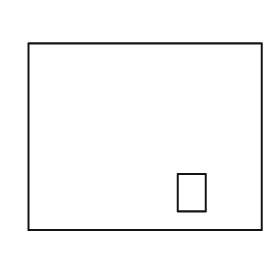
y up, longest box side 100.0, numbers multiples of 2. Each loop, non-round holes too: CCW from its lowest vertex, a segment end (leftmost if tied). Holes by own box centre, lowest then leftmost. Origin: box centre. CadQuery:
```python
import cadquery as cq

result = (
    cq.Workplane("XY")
    .moveTo(-50.0, -40.0)
    .lineTo(50.0, -40.0)
    .lineTo(50.0, 40.0)
    .lineTo(-50.0, 40.0)
    .close()
    .moveTo(14.0, -32.0)
    .lineTo(26.0, -32.0)
    .lineTo(26.0, -16.0)
    .lineTo(14.0, -16.0)
    .close()
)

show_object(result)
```